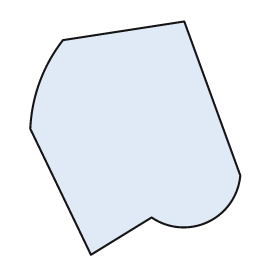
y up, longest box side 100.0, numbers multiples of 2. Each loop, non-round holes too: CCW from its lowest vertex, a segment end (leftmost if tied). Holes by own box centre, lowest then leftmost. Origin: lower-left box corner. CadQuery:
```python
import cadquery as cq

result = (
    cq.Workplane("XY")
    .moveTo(26.0, 0.0)
    .lineTo(52.0, 16.0)
    .threePointArc((76.0, 14.0), (90.0, 34.0))
    .lineTo(66.0, 100.0)
    .lineTo(14.0, 92.0)
    .threePointArc((4.0, 74.0), (0.0, 54.0))
    .close()
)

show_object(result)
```